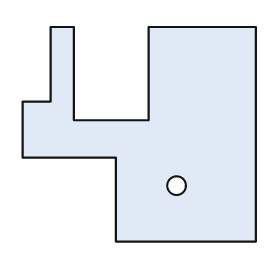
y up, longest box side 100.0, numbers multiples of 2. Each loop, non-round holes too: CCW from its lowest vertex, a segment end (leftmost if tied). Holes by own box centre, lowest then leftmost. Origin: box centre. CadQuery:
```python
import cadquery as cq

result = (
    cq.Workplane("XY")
    .moveTo(-10.0, -46.0)
    .lineTo(50.0, -46.0)
    .lineTo(50.0, 46.0)
    .lineTo(4.0, 46.0)
    .lineTo(4.0, 6.0)
    .lineTo(-28.0, 6.0)
    .lineTo(-28.0, 46.0)
    .lineTo(-38.0, 46.0)
    .lineTo(-38.0, 14.0)
    .lineTo(-50.0, 14.0)
    .lineTo(-50.0, -10.0)
    .lineTo(-10.0, -10.0)
    .close()
    .moveTo(16.0, -22.0)
    .circle(4.0)
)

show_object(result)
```